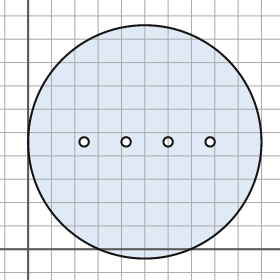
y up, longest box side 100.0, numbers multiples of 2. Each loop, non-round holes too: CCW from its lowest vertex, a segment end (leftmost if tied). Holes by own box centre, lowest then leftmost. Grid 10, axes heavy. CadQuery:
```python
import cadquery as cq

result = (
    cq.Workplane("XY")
    .moveTo(50.0, 46.0)
    .circle(50.0)
    .moveTo(24.0, 46.0)
    .circle(2.0)
    .moveTo(42.0, 46.0)
    .circle(2.0)
    .moveTo(60.0, 46.0)
    .circle(2.0)
    .moveTo(78.0, 46.0)
    .circle(2.0)
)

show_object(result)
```